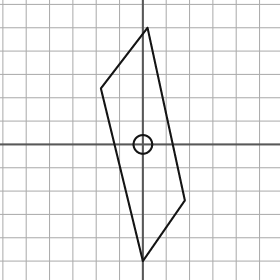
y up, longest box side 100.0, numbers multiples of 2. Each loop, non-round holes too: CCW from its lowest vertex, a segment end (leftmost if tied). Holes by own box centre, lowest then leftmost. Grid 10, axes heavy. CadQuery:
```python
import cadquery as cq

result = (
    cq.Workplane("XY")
    .moveTo(0.0, -50.0)
    .lineTo(18.0, -24.0)
    .lineTo(2.0, 50.0)
    .lineTo(-18.0, 24.0)
    .close()
    .moveTo(0.0, 0.0)
    .circle(4.0)
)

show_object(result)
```